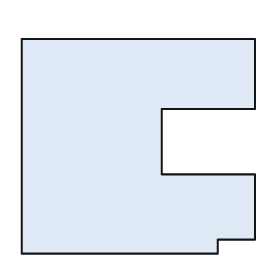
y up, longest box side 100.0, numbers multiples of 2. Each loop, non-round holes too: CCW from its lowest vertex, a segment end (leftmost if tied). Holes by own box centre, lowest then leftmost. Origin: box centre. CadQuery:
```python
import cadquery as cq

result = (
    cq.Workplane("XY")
    .moveTo(-50.0, -46.0)
    .lineTo(34.0, -46.0)
    .lineTo(34.0, -40.0)
    .lineTo(50.0, -40.0)
    .lineTo(50.0, -12.0)
    .lineTo(10.0, -12.0)
    .lineTo(10.0, 16.0)
    .lineTo(50.0, 16.0)
    .lineTo(50.0, 46.0)
    .lineTo(-50.0, 46.0)
    .close()
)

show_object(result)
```